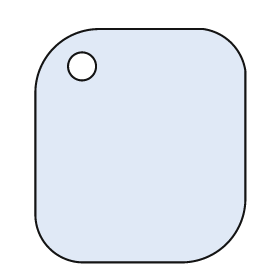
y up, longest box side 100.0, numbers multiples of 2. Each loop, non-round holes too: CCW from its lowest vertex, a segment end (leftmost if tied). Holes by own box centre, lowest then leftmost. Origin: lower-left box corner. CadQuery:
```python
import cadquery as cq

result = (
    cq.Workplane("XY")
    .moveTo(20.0, 0.0)
    .lineTo(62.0, 0.0)
    .threePointArc((82.0, 8.0), (90.0, 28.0))
    .lineTo(90.0, 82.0)
    .threePointArc((84.0, 94.0), (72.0, 100.0))
    .lineTo(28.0, 100.0)
    .threePointArc((8.0, 92.0), (0.0, 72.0))
    .lineTo(0.0, 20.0)
    .threePointArc((6.0, 6.0), (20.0, 0.0))
    .close()
    .moveTo(20.0, 84.0)
    .circle(6.0)
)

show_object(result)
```